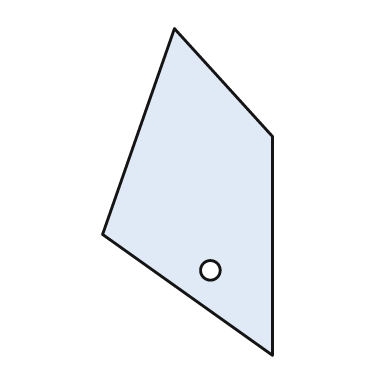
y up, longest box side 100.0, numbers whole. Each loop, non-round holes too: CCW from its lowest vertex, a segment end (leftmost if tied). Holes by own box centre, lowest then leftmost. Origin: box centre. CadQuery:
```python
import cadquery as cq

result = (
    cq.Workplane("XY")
    .moveTo(26.0, -50.0)
    .lineTo(26.0, 17.0)
    .lineTo(-4.0, 50.0)
    .lineTo(-26.0, -13.0)
    .close()
    .moveTo(7.0, -24.0)
    .circle(3.0)
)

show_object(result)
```